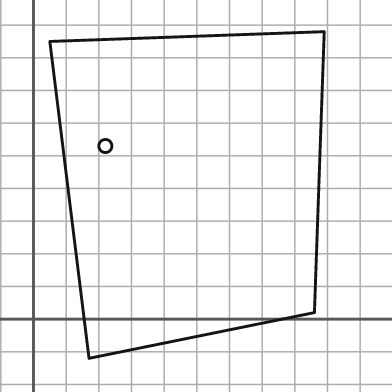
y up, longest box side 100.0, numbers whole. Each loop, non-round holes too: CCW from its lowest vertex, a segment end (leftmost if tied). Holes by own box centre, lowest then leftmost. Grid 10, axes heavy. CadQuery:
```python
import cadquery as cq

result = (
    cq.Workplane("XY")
    .moveTo(17.0, -12.0)
    .lineTo(86.0, 2.0)
    .lineTo(89.0, 88.0)
    .lineTo(5.0, 85.0)
    .close()
    .moveTo(22.0, 53.0)
    .circle(2.0)
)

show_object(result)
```